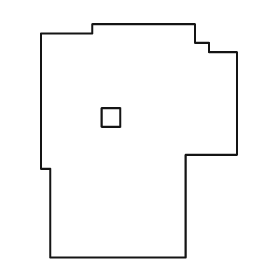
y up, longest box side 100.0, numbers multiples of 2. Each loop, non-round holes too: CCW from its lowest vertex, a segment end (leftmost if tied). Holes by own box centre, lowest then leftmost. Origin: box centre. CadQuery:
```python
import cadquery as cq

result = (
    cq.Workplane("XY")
    .moveTo(-38.0, -50.0)
    .lineTo(20.0, -50.0)
    .lineTo(20.0, -6.0)
    .lineTo(42.0, -6.0)
    .lineTo(42.0, 38.0)
    .lineTo(30.0, 38.0)
    .lineTo(30.0, 42.0)
    .lineTo(24.0, 42.0)
    .lineTo(24.0, 50.0)
    .lineTo(-20.0, 50.0)
    .lineTo(-20.0, 46.0)
    .lineTo(-42.0, 46.0)
    .lineTo(-42.0, -12.0)
    .lineTo(-38.0, -12.0)
    .close()
    .moveTo(-16.0, 6.0)
    .lineTo(-8.0, 6.0)
    .lineTo(-8.0, 14.0)
    .lineTo(-16.0, 14.0)
    .close()
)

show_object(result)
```